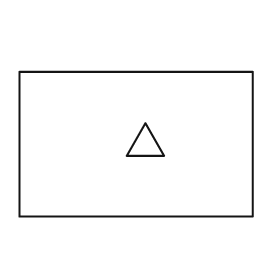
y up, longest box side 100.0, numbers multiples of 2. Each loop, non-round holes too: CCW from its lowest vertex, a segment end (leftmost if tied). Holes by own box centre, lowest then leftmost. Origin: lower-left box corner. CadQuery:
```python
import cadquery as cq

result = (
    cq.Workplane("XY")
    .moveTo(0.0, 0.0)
    .lineTo(100.0, 0.0)
    .lineTo(100.0, 62.0)
    .lineTo(0.0, 62.0)
    .close()
    .moveTo(46.0, 26.0)
    .lineTo(62.0, 26.0)
    .lineTo(54.0, 40.0)
    .close()
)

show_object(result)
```